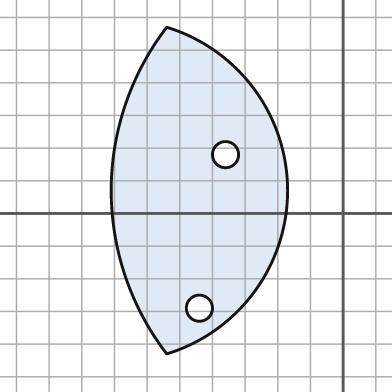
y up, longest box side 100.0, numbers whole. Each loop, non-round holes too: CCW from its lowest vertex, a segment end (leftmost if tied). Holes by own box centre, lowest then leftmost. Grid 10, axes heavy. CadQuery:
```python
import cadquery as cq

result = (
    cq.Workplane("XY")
    .moveTo(-54.0, -43.0)
    .threePointArc((-17.0, 7.0), (-54.0, 57.0))
    .threePointArc((-71.0, 7.0), (-54.0, -43.0))
    .close()
    .moveTo(-44.0, -29.0)
    .circle(4.0)
    .moveTo(-36.0, 18.0)
    .circle(4.0)
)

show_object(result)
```